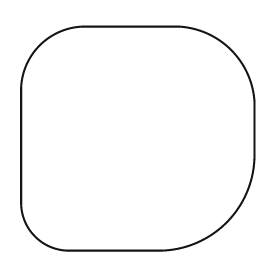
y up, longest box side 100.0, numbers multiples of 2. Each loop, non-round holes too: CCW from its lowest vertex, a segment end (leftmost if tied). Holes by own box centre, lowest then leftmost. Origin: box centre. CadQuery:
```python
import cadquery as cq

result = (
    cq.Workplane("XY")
    .moveTo(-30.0, -48.0)
    .lineTo(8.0, -48.0)
    .threePointArc((38.0, -36.0), (50.0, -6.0))
    .lineTo(50.0, 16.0)
    .threePointArc((40.0, 38.0), (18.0, 48.0))
    .lineTo(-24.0, 48.0)
    .threePointArc((-42.0, 40.0), (-50.0, 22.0))
    .lineTo(-50.0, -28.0)
    .threePointArc((-44.0, -42.0), (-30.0, -48.0))
    .close()
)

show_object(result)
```